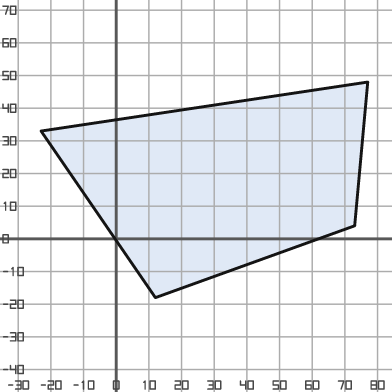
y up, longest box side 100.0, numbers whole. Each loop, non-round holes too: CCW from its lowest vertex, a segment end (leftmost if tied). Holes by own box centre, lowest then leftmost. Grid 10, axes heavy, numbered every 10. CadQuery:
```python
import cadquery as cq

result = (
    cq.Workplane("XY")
    .moveTo(12.0, -18.0)
    .lineTo(73.0, 4.0)
    .lineTo(77.0, 48.0)
    .lineTo(-23.0, 33.0)
    .close()
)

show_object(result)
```